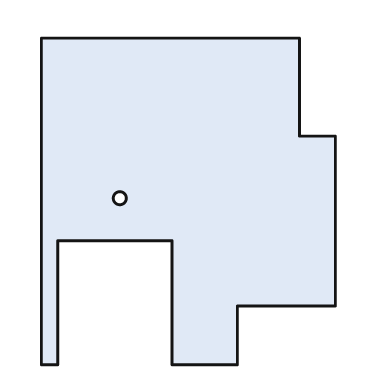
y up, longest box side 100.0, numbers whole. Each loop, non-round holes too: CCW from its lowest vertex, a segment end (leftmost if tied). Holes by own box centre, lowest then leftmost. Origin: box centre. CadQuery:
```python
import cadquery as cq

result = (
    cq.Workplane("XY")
    .moveTo(-45.0, -50.0)
    .lineTo(-40.0, -50.0)
    .lineTo(-40.0, -12.0)
    .lineTo(-5.0, -12.0)
    .lineTo(-5.0, -50.0)
    .lineTo(15.0, -50.0)
    .lineTo(15.0, -32.0)
    .lineTo(45.0, -32.0)
    .lineTo(45.0, 20.0)
    .lineTo(34.0, 20.0)
    .lineTo(34.0, 50.0)
    .lineTo(-45.0, 50.0)
    .close()
    .moveTo(-21.0, 1.0)
    .circle(2.0)
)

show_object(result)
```